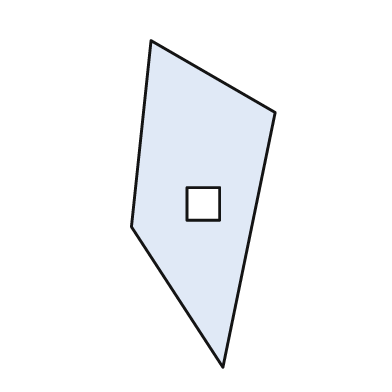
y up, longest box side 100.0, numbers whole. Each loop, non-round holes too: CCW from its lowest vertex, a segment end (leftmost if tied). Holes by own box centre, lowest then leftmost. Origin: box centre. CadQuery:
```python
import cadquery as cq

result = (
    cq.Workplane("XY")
    .moveTo(6.0, -50.0)
    .lineTo(22.0, 28.0)
    .lineTo(-16.0, 50.0)
    .lineTo(-22.0, -7.0)
    .close()
    .moveTo(-5.0, -5.0)
    .lineTo(5.0, -5.0)
    .lineTo(5.0, 5.0)
    .lineTo(-5.0, 5.0)
    .close()
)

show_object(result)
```